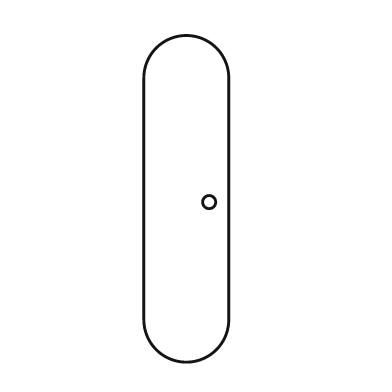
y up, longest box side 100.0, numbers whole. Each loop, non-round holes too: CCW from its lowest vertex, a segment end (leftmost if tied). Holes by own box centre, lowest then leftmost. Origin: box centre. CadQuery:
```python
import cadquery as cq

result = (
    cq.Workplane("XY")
    .moveTo(-13.0, -37.0)
    .threePointArc((0.0, -50.0), (13.0, -37.0))
    .lineTo(13.0, 37.0)
    .threePointArc((0.0, 50.0), (-13.0, 37.0))
    .close()
    .moveTo(7.0, -1.0)
    .circle(2.0)
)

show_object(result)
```